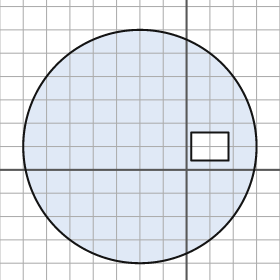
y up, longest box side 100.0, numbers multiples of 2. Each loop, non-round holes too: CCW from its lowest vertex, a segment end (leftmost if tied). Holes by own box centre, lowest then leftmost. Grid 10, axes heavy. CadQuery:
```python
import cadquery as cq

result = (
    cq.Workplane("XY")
    .moveTo(-20.0, 10.0)
    .circle(50.0)
    .moveTo(2.0, 4.0)
    .lineTo(18.0, 4.0)
    .lineTo(18.0, 16.0)
    .lineTo(2.0, 16.0)
    .close()
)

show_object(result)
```